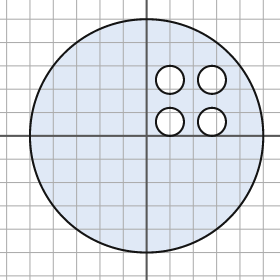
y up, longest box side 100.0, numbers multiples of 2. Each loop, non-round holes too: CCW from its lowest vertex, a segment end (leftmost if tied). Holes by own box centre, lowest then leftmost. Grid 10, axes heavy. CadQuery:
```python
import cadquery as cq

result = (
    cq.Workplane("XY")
    .moveTo(0.0, 0.0)
    .circle(50.0)
    .moveTo(10.0, 6.0)
    .circle(6.0)
    .moveTo(28.0, 6.0)
    .circle(6.0)
    .moveTo(10.0, 24.0)
    .circle(6.0)
    .moveTo(28.0, 24.0)
    .circle(6.0)
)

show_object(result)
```